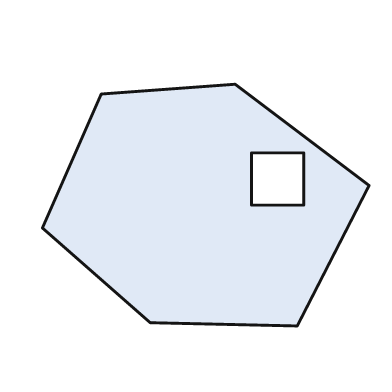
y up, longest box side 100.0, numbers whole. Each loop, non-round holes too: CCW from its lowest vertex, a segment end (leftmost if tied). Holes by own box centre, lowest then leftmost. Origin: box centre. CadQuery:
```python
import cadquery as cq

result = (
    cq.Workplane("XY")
    .moveTo(28.0, -37.0)
    .lineTo(50.0, 6.0)
    .lineTo(9.0, 37.0)
    .lineTo(-32.0, 34.0)
    .lineTo(-50.0, -7.0)
    .lineTo(-17.0, -36.0)
    .close()
    .moveTo(14.0, 0.0)
    .lineTo(30.0, 0.0)
    .lineTo(30.0, 16.0)
    .lineTo(14.0, 16.0)
    .close()
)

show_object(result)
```